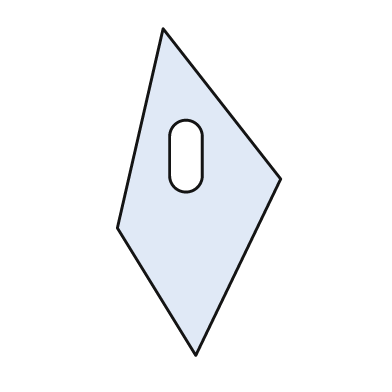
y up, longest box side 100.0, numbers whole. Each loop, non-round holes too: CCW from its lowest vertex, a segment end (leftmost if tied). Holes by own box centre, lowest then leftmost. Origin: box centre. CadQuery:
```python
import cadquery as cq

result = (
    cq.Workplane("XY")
    .moveTo(-1.0, -50.0)
    .lineTo(25.0, 4.0)
    .lineTo(-11.0, 50.0)
    .lineTo(-25.0, -11.0)
    .close()
    .moveTo(-9.0, 5.0)
    .threePointArc((-4.0, 0.0), (1.0, 5.0))
    .lineTo(1.0, 17.0)
    .threePointArc((-4.0, 22.0), (-9.0, 17.0))
    .close()
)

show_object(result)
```